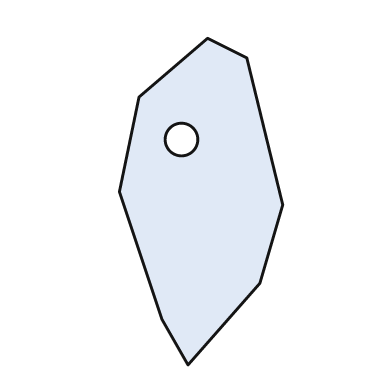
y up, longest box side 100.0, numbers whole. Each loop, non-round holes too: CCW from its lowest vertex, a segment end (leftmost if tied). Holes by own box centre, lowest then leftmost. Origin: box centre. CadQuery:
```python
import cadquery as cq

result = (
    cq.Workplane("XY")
    .moveTo(-4.0, -50.0)
    .lineTo(18.0, -25.0)
    .lineTo(25.0, -1.0)
    .lineTo(14.0, 44.0)
    .lineTo(2.0, 50.0)
    .lineTo(-19.0, 32.0)
    .lineTo(-25.0, 3.0)
    .lineTo(-12.0, -36.0)
    .close()
    .moveTo(-6.0, 19.0)
    .circle(5.0)
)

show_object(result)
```